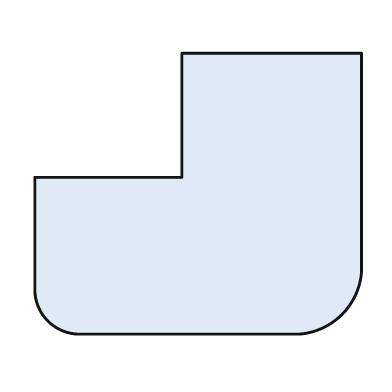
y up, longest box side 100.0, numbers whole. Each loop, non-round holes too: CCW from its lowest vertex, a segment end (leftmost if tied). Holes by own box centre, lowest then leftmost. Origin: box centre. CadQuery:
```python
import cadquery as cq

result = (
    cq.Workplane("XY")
    .moveTo(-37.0, -43.0)
    .lineTo(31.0, -43.0)
    .threePointArc((44.0, -37.0), (50.0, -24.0))
    .lineTo(50.0, 43.0)
    .lineTo(-5.0, 43.0)
    .lineTo(-5.0, 5.0)
    .lineTo(-50.0, 5.0)
    .lineTo(-50.0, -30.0)
    .threePointArc((-46.0, -39.0), (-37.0, -43.0))
    .close()
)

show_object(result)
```